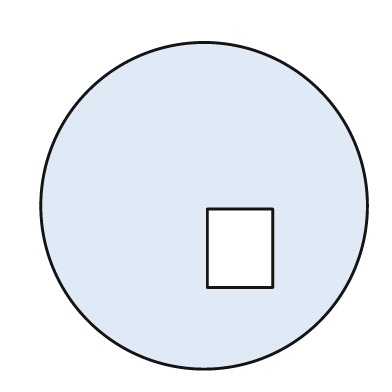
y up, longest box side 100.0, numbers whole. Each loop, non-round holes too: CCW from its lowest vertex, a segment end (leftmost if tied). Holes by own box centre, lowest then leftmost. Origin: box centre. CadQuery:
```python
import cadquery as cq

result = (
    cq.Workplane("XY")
    .moveTo(0.0, 0.0)
    .circle(50.0)
    .moveTo(1.0, -25.0)
    .lineTo(21.0, -25.0)
    .lineTo(21.0, -1.0)
    .lineTo(1.0, -1.0)
    .close()
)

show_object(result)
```